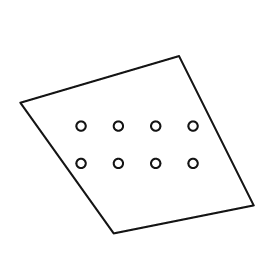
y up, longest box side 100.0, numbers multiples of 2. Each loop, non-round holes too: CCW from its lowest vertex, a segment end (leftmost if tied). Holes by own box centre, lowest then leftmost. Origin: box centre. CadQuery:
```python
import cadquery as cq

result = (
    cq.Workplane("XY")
    .moveTo(-10.0, -38.0)
    .lineTo(50.0, -26.0)
    .lineTo(18.0, 38.0)
    .lineTo(-50.0, 18.0)
    .close()
    .moveTo(-24.0, -8.0)
    .circle(2.0)
    .moveTo(-8.0, -8.0)
    .circle(2.0)
    .moveTo(8.0, -8.0)
    .circle(2.0)
    .moveTo(24.0, -8.0)
    .circle(2.0)
    .moveTo(-24.0, 8.0)
    .circle(2.0)
    .moveTo(-8.0, 8.0)
    .circle(2.0)
    .moveTo(8.0, 8.0)
    .circle(2.0)
    .moveTo(24.0, 8.0)
    .circle(2.0)
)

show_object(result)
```